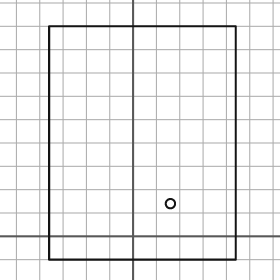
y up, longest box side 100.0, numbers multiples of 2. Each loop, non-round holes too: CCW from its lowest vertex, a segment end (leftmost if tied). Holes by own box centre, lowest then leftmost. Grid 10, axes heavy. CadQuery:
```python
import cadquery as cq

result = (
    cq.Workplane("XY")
    .moveTo(-36.0, -10.0)
    .lineTo(44.0, -10.0)
    .lineTo(44.0, 90.0)
    .lineTo(-36.0, 90.0)
    .close()
    .moveTo(16.0, 14.0)
    .circle(2.0)
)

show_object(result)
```